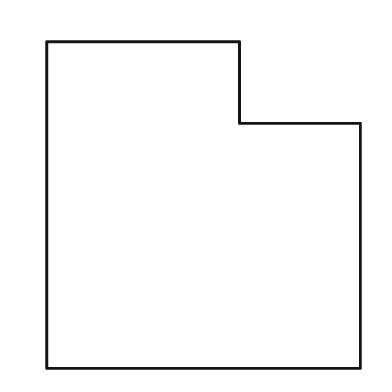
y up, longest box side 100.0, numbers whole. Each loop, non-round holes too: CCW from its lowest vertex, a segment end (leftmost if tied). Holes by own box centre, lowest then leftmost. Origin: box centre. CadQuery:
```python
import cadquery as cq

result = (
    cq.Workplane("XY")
    .moveTo(-48.0, -50.0)
    .lineTo(48.0, -50.0)
    .lineTo(48.0, 25.0)
    .lineTo(11.0, 25.0)
    .lineTo(11.0, 50.0)
    .lineTo(-48.0, 50.0)
    .close()
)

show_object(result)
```